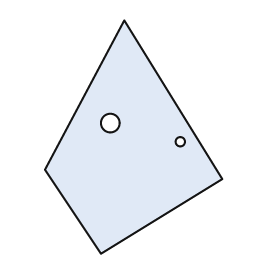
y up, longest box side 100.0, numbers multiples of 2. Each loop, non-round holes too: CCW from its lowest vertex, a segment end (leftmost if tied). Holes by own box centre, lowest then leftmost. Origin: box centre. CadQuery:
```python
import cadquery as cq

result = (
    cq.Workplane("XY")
    .moveTo(-14.0, -50.0)
    .lineTo(38.0, -18.0)
    .lineTo(-4.0, 50.0)
    .lineTo(-38.0, -14.0)
    .close()
    .moveTo(20.0, -2.0)
    .circle(2.0)
    .moveTo(-10.0, 6.0)
    .circle(4.0)
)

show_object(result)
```